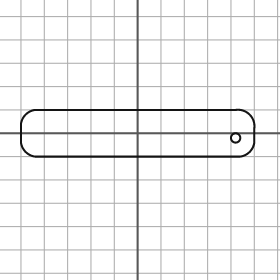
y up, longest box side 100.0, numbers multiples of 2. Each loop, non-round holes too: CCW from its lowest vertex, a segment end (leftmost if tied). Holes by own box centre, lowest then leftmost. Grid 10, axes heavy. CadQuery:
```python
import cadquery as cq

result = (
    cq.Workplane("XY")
    .moveTo(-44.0, -10.0)
    .lineTo(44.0, -10.0)
    .threePointArc((48.0, -8.0), (50.0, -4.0))
    .lineTo(50.0, 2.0)
    .threePointArc((48.0, 8.0), (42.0, 10.0))
    .lineTo(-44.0, 10.0)
    .threePointArc((-48.0, 8.0), (-50.0, 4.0))
    .lineTo(-50.0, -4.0)
    .threePointArc((-48.0, -8.0), (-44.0, -10.0))
    .close()
    .moveTo(42.0, -2.0)
    .circle(2.0)
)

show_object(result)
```